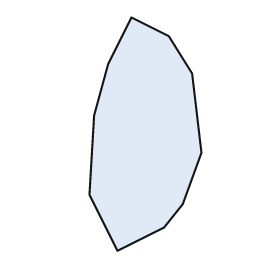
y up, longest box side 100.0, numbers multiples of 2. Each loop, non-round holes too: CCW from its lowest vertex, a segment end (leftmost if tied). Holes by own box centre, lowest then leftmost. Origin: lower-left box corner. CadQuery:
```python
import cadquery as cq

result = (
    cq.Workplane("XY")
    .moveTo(12.0, 0.0)
    .lineTo(32.0, 10.0)
    .lineTo(40.0, 20.0)
    .lineTo(48.0, 42.0)
    .lineTo(44.0, 76.0)
    .lineTo(34.0, 92.0)
    .lineTo(18.0, 100.0)
    .lineTo(8.0, 80.0)
    .lineTo(2.0, 58.0)
    .lineTo(0.0, 24.0)
    .close()
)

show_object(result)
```